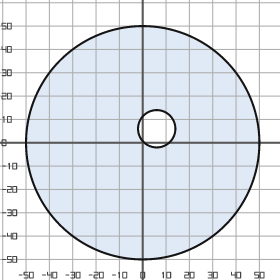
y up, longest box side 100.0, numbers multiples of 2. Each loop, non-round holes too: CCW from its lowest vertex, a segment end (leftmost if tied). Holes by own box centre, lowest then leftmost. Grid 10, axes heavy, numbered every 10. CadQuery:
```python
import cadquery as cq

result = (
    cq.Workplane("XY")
    .moveTo(0.0, 0.0)
    .circle(50.0)
    .moveTo(6.0, 6.0)
    .circle(8.0)
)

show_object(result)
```